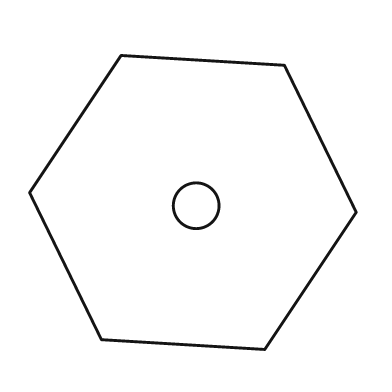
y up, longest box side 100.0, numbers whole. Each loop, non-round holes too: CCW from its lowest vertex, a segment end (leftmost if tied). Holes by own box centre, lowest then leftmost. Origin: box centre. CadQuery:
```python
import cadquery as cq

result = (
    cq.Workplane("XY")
    .moveTo(22.0, -45.0)
    .lineTo(50.0, -3.0)
    .lineTo(28.0, 42.0)
    .lineTo(-22.0, 45.0)
    .lineTo(-50.0, 3.0)
    .lineTo(-28.0, -42.0)
    .close()
    .moveTo(1.0, -1.0)
    .circle(7.0)
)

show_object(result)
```